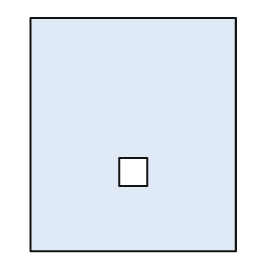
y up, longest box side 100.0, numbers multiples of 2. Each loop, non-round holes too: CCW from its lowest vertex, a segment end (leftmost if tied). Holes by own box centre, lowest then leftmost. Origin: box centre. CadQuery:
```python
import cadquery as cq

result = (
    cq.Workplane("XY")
    .moveTo(-44.0, -50.0)
    .lineTo(44.0, -50.0)
    .lineTo(44.0, 50.0)
    .lineTo(-44.0, 50.0)
    .close()
    .moveTo(-6.0, -22.0)
    .lineTo(6.0, -22.0)
    .lineTo(6.0, -10.0)
    .lineTo(-6.0, -10.0)
    .close()
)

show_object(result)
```